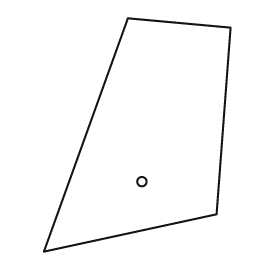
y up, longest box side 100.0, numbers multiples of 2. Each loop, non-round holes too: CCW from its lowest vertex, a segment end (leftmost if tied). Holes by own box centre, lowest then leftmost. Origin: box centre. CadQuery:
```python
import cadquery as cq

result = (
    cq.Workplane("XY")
    .moveTo(-40.0, -50.0)
    .lineTo(34.0, -34.0)
    .lineTo(40.0, 46.0)
    .lineTo(-4.0, 50.0)
    .close()
    .moveTo(2.0, -20.0)
    .circle(2.0)
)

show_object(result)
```